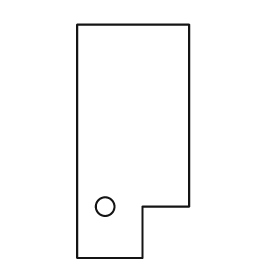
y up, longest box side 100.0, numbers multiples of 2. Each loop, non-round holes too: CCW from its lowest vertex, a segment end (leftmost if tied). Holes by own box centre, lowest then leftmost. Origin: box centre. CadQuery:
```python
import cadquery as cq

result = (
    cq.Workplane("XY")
    .moveTo(-24.0, -50.0)
    .lineTo(4.0, -50.0)
    .lineTo(4.0, -28.0)
    .lineTo(24.0, -28.0)
    .lineTo(24.0, 50.0)
    .lineTo(-24.0, 50.0)
    .close()
    .moveTo(-12.0, -28.0)
    .circle(4.0)
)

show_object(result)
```